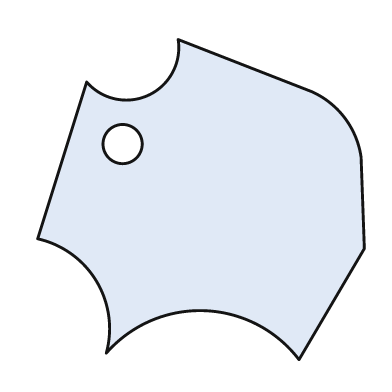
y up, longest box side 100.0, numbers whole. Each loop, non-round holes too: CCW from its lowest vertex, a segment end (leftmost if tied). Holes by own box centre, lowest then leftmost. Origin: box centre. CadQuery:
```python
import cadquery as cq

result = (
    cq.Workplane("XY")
    .moveTo(30.0, -49.0)
    .lineTo(50.0, -15.0)
    .lineTo(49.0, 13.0)
    .threePointArc((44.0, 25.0), (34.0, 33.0))
    .lineTo(-7.0, 49.0)
    .threePointArc((-16.0, 32.0), (-35.0, 36.0))
    .lineTo(-50.0, -12.0)
    .threePointArc((-32.0, -25.0), (-29.0, -47.0))
    .threePointArc((1.0, -34.0), (30.0, -49.0))
    .close()
    .moveTo(-24.0, 17.0)
    .circle(6.0)
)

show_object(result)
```